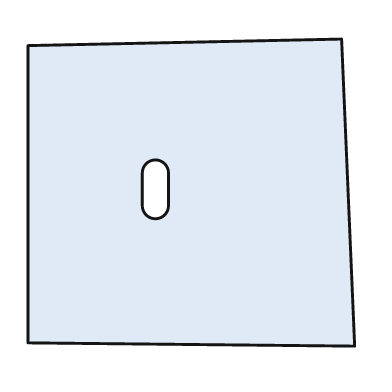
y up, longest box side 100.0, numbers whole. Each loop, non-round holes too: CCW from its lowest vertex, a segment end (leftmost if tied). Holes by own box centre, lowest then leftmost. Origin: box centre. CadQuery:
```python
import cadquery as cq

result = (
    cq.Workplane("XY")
    .moveTo(50.0, -47.0)
    .lineTo(46.0, 47.0)
    .lineTo(-50.0, 45.0)
    .lineTo(-50.0, -46.0)
    .close()
    .moveTo(-15.0, -4.0)
    .threePointArc((-11.0, -8.0), (-7.0, -4.0))
    .lineTo(-7.0, 6.0)
    .threePointArc((-11.0, 10.0), (-15.0, 6.0))
    .close()
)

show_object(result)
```